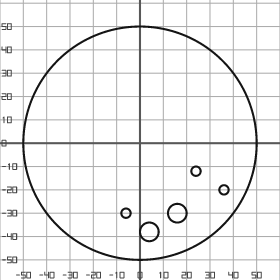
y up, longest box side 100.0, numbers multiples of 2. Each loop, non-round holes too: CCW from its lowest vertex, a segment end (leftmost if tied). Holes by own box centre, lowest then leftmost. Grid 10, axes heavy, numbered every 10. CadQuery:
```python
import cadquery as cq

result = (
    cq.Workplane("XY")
    .moveTo(0.0, 0.0)
    .circle(50.0)
    .moveTo(4.0, -38.0)
    .circle(4.0)
    .moveTo(-6.0, -30.0)
    .circle(2.0)
    .moveTo(16.0, -30.0)
    .circle(4.0)
    .moveTo(36.0, -20.0)
    .circle(2.0)
    .moveTo(24.0, -12.0)
    .circle(2.0)
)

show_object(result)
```